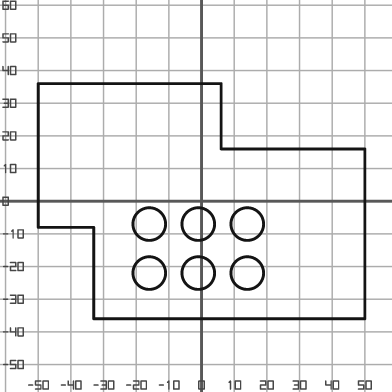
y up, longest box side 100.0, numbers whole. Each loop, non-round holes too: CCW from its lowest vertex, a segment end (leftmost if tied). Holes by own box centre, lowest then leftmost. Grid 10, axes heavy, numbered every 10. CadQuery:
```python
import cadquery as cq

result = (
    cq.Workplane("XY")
    .moveTo(-33.0, -36.0)
    .lineTo(50.0, -36.0)
    .lineTo(50.0, 16.0)
    .lineTo(6.0, 16.0)
    .lineTo(6.0, 36.0)
    .lineTo(-50.0, 36.0)
    .lineTo(-50.0, -8.0)
    .lineTo(-33.0, -8.0)
    .close()
    .moveTo(-16.0, -22.0)
    .circle(5.0)
    .moveTo(-1.0, -22.0)
    .circle(5.0)
    .moveTo(14.0, -22.0)
    .circle(5.0)
    .moveTo(-16.0, -7.0)
    .circle(5.0)
    .moveTo(-1.0, -7.0)
    .circle(5.0)
    .moveTo(14.0, -7.0)
    .circle(5.0)
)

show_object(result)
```